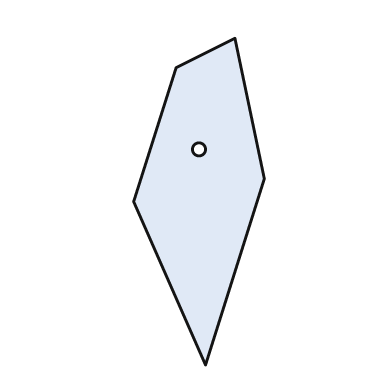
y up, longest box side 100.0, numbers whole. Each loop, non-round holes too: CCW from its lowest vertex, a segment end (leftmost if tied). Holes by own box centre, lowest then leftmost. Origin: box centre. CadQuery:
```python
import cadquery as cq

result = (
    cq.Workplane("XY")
    .moveTo(2.0, -50.0)
    .lineTo(20.0, 7.0)
    .lineTo(11.0, 50.0)
    .lineTo(-7.0, 41.0)
    .lineTo(-20.0, 0.0)
    .close()
    .moveTo(0.0, 16.0)
    .circle(2.0)
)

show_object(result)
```